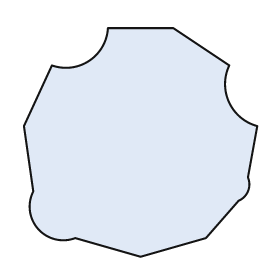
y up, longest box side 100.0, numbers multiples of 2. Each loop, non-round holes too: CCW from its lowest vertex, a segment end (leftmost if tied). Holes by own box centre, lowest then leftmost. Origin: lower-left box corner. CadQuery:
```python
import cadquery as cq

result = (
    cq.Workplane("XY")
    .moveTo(50.0, 0.0)
    .lineTo(78.0, 8.0)
    .lineTo(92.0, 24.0)
    .threePointArc((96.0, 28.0), (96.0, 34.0))
    .lineTo(100.0, 56.0)
    .threePointArc((88.0, 66.0), (88.0, 82.0))
    .lineTo(64.0, 98.0)
    .lineTo(36.0, 98.0)
    .threePointArc((28.0, 84.0), (12.0, 82.0))
    .lineTo(0.0, 56.0)
    .lineTo(4.0, 28.0)
    .threePointArc((6.0, 12.0), (22.0, 8.0))
    .close()
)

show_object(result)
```